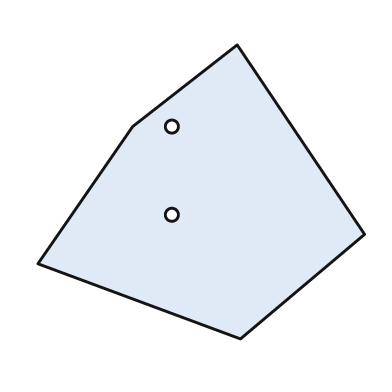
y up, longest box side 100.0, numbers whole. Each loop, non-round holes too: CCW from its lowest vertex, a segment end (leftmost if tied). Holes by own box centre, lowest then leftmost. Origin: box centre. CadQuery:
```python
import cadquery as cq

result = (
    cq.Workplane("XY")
    .moveTo(12.0, -45.0)
    .lineTo(50.0, -13.0)
    .lineTo(11.0, 45.0)
    .lineTo(-21.0, 20.0)
    .lineTo(-50.0, -22.0)
    .close()
    .moveTo(-9.0, -7.0)
    .circle(2.0)
    .moveTo(-9.0, 20.0)
    .circle(2.0)
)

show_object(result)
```